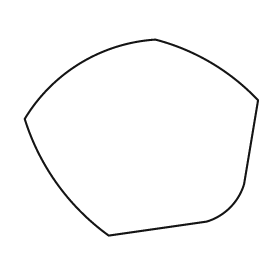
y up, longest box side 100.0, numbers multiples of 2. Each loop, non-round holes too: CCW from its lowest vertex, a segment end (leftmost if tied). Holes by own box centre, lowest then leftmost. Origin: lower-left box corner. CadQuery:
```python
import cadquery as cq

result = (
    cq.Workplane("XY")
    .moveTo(36.0, 0.0)
    .lineTo(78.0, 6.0)
    .threePointArc((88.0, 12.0), (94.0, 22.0))
    .lineTo(100.0, 58.0)
    .threePointArc((80.0, 74.0), (56.0, 84.0))
    .threePointArc((24.0, 74.0), (0.0, 50.0))
    .threePointArc((14.0, 22.0), (36.0, 0.0))
    .close()
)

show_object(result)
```